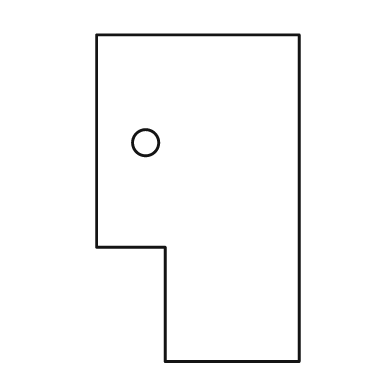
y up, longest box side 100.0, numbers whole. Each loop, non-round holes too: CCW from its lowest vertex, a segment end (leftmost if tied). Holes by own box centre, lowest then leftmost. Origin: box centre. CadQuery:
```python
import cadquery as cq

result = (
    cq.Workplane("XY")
    .moveTo(-10.0, -50.0)
    .lineTo(31.0, -50.0)
    .lineTo(31.0, 50.0)
    .lineTo(-31.0, 50.0)
    .lineTo(-31.0, -15.0)
    .lineTo(-10.0, -15.0)
    .close()
    .moveTo(-16.0, 17.0)
    .circle(4.0)
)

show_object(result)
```